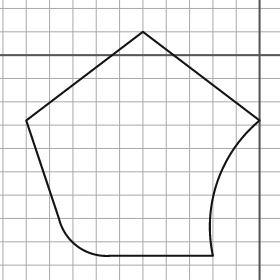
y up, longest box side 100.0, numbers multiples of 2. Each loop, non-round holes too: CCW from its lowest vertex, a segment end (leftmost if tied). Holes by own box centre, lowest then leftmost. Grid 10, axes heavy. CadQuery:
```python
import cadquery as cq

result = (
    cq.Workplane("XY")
    .moveTo(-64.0, -86.0)
    .lineTo(-20.0, -86.0)
    .threePointArc((-18.0, -54.0), (0.0, -28.0))
    .lineTo(-50.0, 10.0)
    .lineTo(-100.0, -28.0)
    .lineTo(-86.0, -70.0)
    .threePointArc((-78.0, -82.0), (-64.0, -86.0))
    .close()
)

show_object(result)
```